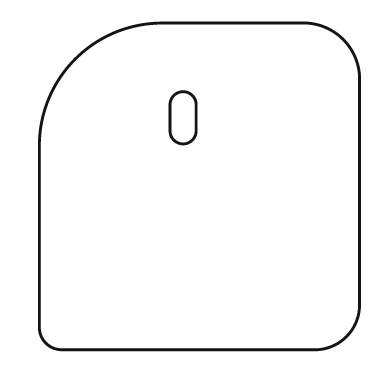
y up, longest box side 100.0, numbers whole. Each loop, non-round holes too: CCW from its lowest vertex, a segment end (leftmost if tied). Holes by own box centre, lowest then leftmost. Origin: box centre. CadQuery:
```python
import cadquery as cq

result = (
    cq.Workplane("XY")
    .moveTo(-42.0, -50.0)
    .lineTo(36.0, -50.0)
    .threePointArc((45.0, -46.0), (49.0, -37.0))
    .lineTo(49.0, 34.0)
    .threePointArc((44.0, 45.0), (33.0, 50.0))
    .lineTo(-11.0, 50.0)
    .threePointArc((-38.0, 39.0), (-49.0, 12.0))
    .lineTo(-49.0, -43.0)
    .threePointArc((-47.0, -48.0), (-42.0, -50.0))
    .close()
    .moveTo(-9.0, 17.0)
    .threePointArc((-5.0, 13.0), (-1.0, 17.0))
    .lineTo(-1.0, 25.0)
    .threePointArc((-5.0, 29.0), (-9.0, 25.0))
    .close()
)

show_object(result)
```